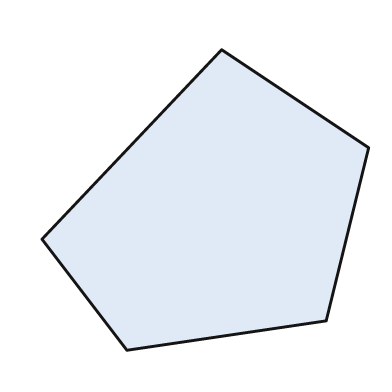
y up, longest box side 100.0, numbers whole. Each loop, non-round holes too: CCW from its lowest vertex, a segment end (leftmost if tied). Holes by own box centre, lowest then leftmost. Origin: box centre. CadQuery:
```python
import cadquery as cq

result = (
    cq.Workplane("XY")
    .moveTo(-24.0, -46.0)
    .lineTo(37.0, -37.0)
    .lineTo(50.0, 16.0)
    .lineTo(5.0, 46.0)
    .lineTo(-50.0, -12.0)
    .close()
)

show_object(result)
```